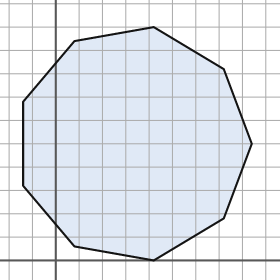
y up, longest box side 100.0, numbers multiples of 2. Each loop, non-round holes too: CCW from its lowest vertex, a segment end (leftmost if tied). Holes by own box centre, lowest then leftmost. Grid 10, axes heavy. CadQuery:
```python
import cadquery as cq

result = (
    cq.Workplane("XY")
    .moveTo(42.0, 0.0)
    .lineTo(72.0, 18.0)
    .lineTo(84.0, 50.0)
    .lineTo(72.0, 82.0)
    .lineTo(42.0, 100.0)
    .lineTo(8.0, 94.0)
    .lineTo(-14.0, 68.0)
    .lineTo(-14.0, 32.0)
    .lineTo(8.0, 6.0)
    .close()
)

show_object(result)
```